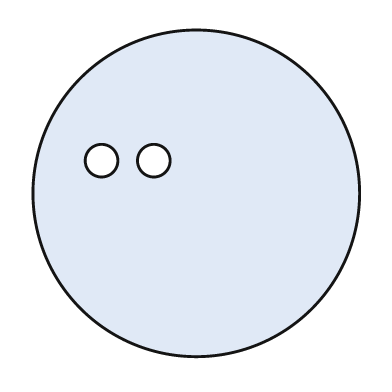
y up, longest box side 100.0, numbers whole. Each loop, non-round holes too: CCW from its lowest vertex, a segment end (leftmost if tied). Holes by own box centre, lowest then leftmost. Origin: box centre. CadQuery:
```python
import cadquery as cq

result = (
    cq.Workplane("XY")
    .moveTo(0.0, 0.0)
    .circle(50.0)
    .moveTo(-29.0, 10.0)
    .circle(5.0)
    .moveTo(-13.0, 10.0)
    .circle(5.0)
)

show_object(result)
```